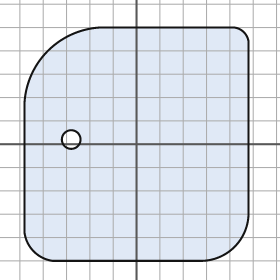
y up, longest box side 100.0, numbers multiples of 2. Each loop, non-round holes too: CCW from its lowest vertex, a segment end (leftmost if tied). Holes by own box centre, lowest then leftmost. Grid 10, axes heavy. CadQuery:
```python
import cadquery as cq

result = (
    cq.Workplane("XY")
    .moveTo(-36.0, -50.0)
    .lineTo(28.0, -50.0)
    .threePointArc((42.0, -44.0), (48.0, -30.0))
    .lineTo(48.0, 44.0)
    .threePointArc((46.0, 48.0), (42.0, 50.0))
    .lineTo(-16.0, 50.0)
    .threePointArc((-38.0, 40.0), (-48.0, 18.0))
    .lineTo(-48.0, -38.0)
    .threePointArc((-44.0, -46.0), (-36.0, -50.0))
    .close()
    .moveTo(-28.0, 2.0)
    .circle(4.0)
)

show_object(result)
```